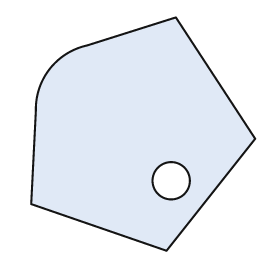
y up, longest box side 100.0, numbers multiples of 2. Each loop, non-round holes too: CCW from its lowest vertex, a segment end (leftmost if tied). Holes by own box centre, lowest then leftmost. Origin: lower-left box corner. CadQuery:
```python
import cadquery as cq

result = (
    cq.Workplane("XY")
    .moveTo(58.0, 0.0)
    .lineTo(96.0, 48.0)
    .lineTo(62.0, 100.0)
    .lineTo(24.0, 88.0)
    .threePointArc((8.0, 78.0), (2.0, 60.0))
    .lineTo(0.0, 20.0)
    .close()
    .moveTo(60.0, 30.0)
    .circle(8.0)
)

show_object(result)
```